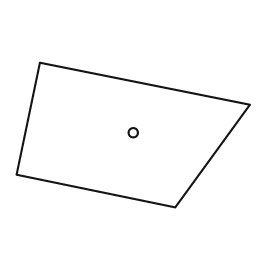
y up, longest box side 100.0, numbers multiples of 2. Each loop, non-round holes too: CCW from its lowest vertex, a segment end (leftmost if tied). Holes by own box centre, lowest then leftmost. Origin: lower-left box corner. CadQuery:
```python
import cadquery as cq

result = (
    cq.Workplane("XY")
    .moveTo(68.0, 0.0)
    .lineTo(100.0, 44.0)
    .lineTo(10.0, 62.0)
    .lineTo(0.0, 14.0)
    .close()
    .moveTo(50.0, 32.0)
    .circle(2.0)
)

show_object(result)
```